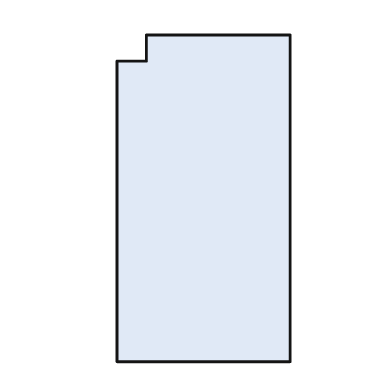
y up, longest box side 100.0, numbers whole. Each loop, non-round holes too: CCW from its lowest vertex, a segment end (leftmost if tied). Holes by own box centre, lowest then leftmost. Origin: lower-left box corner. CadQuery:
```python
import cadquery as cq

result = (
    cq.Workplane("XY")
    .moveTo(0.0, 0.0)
    .lineTo(53.0, 0.0)
    .lineTo(53.0, 100.0)
    .lineTo(9.0, 100.0)
    .lineTo(9.0, 92.0)
    .lineTo(0.0, 92.0)
    .close()
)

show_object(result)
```